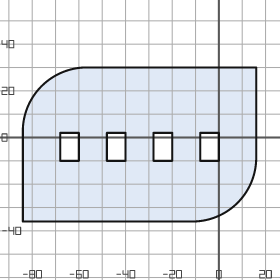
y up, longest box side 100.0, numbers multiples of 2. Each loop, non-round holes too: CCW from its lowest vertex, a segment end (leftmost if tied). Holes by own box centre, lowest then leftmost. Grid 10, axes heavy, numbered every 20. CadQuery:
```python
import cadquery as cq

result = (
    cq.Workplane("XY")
    .moveTo(-84.0, -36.0)
    .lineTo(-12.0, -36.0)
    .threePointArc((8.0, -28.0), (16.0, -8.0))
    .lineTo(16.0, 30.0)
    .lineTo(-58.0, 30.0)
    .threePointArc((-76.0, 22.0), (-84.0, 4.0))
    .close()
    .moveTo(-68.0, -10.0)
    .lineTo(-60.0, -10.0)
    .lineTo(-60.0, 2.0)
    .lineTo(-68.0, 2.0)
    .close()
    .moveTo(-48.0, -10.0)
    .lineTo(-40.0, -10.0)
    .lineTo(-40.0, 2.0)
    .lineTo(-48.0, 2.0)
    .close()
    .moveTo(-28.0, -10.0)
    .lineTo(-20.0, -10.0)
    .lineTo(-20.0, 2.0)
    .lineTo(-28.0, 2.0)
    .close()
    .moveTo(-8.0, -10.0)
    .lineTo(0.0, -10.0)
    .lineTo(0.0, 2.0)
    .lineTo(-8.0, 2.0)
    .close()
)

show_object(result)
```